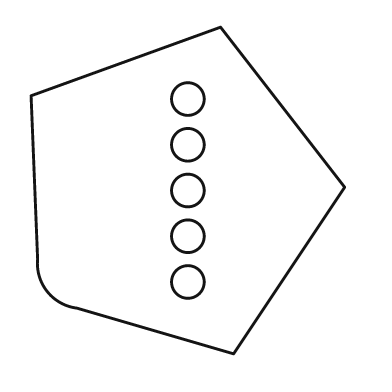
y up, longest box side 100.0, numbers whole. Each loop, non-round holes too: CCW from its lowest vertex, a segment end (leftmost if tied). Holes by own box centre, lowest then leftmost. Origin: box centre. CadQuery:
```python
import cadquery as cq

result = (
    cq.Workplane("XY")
    .moveTo(14.0, -50.0)
    .lineTo(48.0, 1.0)
    .lineTo(10.0, 50.0)
    .lineTo(-48.0, 29.0)
    .lineTo(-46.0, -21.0)
    .threePointArc((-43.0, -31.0), (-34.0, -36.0))
    .close()
    .moveTo(0.0, -28.0)
    .circle(5.0)
    .moveTo(0.0, -14.0)
    .circle(5.0)
    .moveTo(0.0, 0.0)
    .circle(5.0)
    .moveTo(0.0, 14.0)
    .circle(5.0)
    .moveTo(0.0, 28.0)
    .circle(5.0)
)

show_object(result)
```